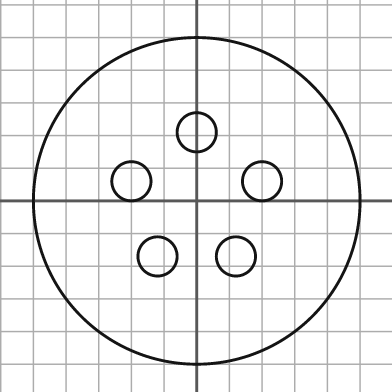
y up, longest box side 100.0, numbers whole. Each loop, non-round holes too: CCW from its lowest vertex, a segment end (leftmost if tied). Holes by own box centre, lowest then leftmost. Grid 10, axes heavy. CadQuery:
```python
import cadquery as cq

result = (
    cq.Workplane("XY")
    .moveTo(0.0, 0.0)
    .circle(50.0)
    .moveTo(-12.0, -17.0)
    .circle(6.0)
    .moveTo(12.0, -17.0)
    .circle(6.0)
    .moveTo(-20.0, 6.0)
    .circle(6.0)
    .moveTo(20.0, 6.0)
    .circle(6.0)
    .moveTo(0.0, 21.0)
    .circle(6.0)
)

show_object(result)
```